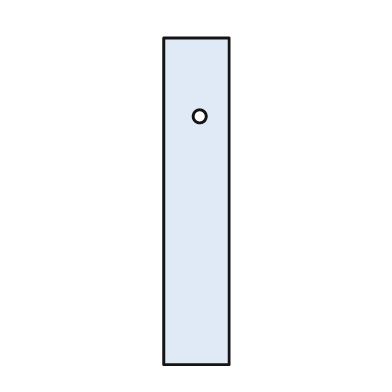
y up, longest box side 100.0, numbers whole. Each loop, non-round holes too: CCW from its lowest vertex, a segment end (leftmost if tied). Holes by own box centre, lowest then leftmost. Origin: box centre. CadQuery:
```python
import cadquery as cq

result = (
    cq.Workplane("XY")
    .moveTo(-10.0, -50.0)
    .lineTo(10.0, -50.0)
    .lineTo(10.0, 50.0)
    .lineTo(-10.0, 50.0)
    .close()
    .moveTo(1.0, 26.0)
    .circle(2.0)
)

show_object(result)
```